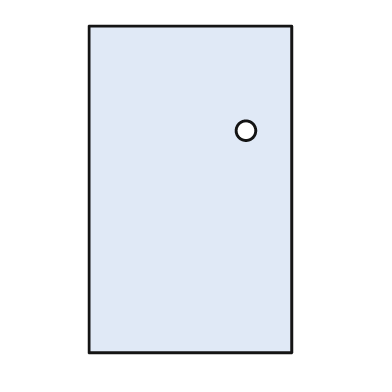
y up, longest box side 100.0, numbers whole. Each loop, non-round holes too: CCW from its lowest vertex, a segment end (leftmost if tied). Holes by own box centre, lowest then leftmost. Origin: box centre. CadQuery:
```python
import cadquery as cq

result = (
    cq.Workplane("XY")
    .moveTo(-31.0, -50.0)
    .lineTo(31.0, -50.0)
    .lineTo(31.0, 50.0)
    .lineTo(-31.0, 50.0)
    .close()
    .moveTo(17.0, 18.0)
    .circle(3.0)
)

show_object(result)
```